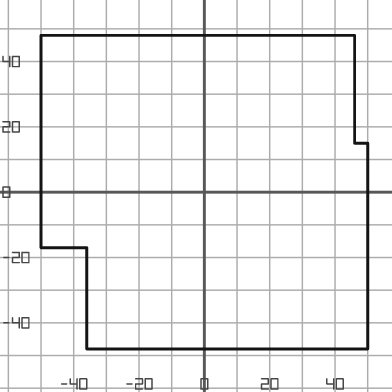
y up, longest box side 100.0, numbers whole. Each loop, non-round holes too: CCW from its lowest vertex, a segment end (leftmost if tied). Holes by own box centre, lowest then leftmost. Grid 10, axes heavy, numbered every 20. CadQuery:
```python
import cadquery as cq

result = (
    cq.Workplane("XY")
    .moveTo(-36.0, -48.0)
    .lineTo(50.0, -48.0)
    .lineTo(50.0, 15.0)
    .lineTo(46.0, 15.0)
    .lineTo(46.0, 48.0)
    .lineTo(-50.0, 48.0)
    .lineTo(-50.0, -17.0)
    .lineTo(-36.0, -17.0)
    .close()
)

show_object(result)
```